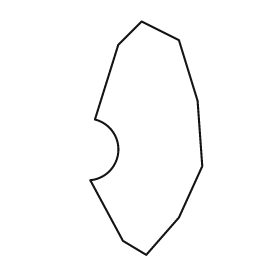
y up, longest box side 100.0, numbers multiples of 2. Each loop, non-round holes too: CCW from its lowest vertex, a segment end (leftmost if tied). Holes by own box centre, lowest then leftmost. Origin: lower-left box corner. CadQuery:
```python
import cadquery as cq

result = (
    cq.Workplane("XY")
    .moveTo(24.0, 0.0)
    .lineTo(38.0, 16.0)
    .lineTo(48.0, 38.0)
    .lineTo(46.0, 66.0)
    .lineTo(38.0, 92.0)
    .lineTo(22.0, 100.0)
    .lineTo(12.0, 90.0)
    .lineTo(2.0, 58.0)
    .threePointArc((12.0, 44.0), (0.0, 32.0))
    .lineTo(14.0, 6.0)
    .close()
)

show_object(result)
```